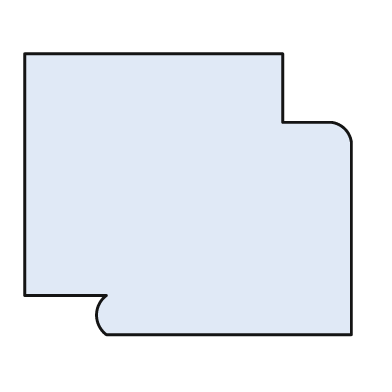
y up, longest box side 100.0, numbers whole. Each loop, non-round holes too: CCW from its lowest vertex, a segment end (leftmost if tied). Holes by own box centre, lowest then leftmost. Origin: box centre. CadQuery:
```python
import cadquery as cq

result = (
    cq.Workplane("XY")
    .moveTo(-25.0, -43.0)
    .lineTo(50.0, -43.0)
    .lineTo(50.0, 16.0)
    .threePointArc((48.0, 20.0), (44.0, 22.0))
    .lineTo(29.0, 22.0)
    .lineTo(29.0, 43.0)
    .lineTo(-50.0, 43.0)
    .lineTo(-50.0, -31.0)
    .lineTo(-25.0, -31.0)
    .threePointArc((-28.0, -37.0), (-25.0, -43.0))
    .close()
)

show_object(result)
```